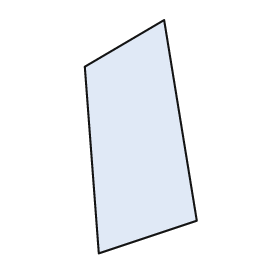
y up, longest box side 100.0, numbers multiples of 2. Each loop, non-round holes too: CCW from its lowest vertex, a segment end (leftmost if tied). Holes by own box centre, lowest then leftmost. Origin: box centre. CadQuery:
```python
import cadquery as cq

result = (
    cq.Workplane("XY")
    .moveTo(-18.0, -50.0)
    .lineTo(24.0, -36.0)
    .lineTo(10.0, 50.0)
    .lineTo(-24.0, 30.0)
    .close()
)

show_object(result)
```